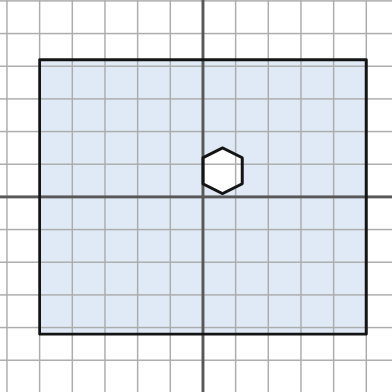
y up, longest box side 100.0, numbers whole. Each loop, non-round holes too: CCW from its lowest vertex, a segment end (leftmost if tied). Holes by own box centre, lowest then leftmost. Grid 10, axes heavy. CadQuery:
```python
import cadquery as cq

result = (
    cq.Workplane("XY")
    .moveTo(-50.0, -42.0)
    .lineTo(50.0, -42.0)
    .lineTo(50.0, 42.0)
    .lineTo(-50.0, 42.0)
    .close()
    .moveTo(6.0, 1.0)
    .lineTo(12.0, 4.0)
    .lineTo(12.0, 12.0)
    .lineTo(6.0, 15.0)
    .lineTo(0.0, 12.0)
    .lineTo(0.0, 4.0)
    .close()
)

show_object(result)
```